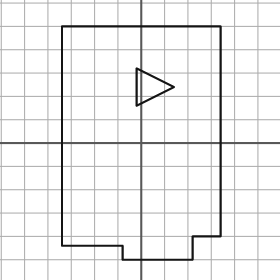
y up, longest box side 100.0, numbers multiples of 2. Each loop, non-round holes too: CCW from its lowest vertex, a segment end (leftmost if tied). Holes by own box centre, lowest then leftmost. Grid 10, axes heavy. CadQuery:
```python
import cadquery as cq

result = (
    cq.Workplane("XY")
    .moveTo(-8.0, -50.0)
    .lineTo(22.0, -50.0)
    .lineTo(22.0, -40.0)
    .lineTo(34.0, -40.0)
    .lineTo(34.0, 50.0)
    .lineTo(-34.0, 50.0)
    .lineTo(-34.0, -44.0)
    .lineTo(-8.0, -44.0)
    .close()
    .moveTo(-2.0, 16.0)
    .lineTo(14.0, 24.0)
    .lineTo(-2.0, 32.0)
    .close()
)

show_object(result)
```